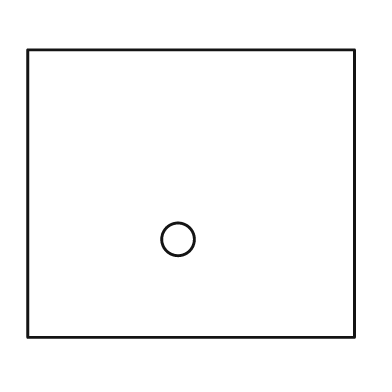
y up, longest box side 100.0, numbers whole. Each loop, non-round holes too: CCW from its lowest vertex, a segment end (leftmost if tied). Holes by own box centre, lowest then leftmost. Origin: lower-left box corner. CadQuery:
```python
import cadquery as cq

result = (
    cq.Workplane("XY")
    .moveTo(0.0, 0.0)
    .lineTo(100.0, 0.0)
    .lineTo(100.0, 88.0)
    .lineTo(0.0, 88.0)
    .close()
    .moveTo(46.0, 30.0)
    .circle(5.0)
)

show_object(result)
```